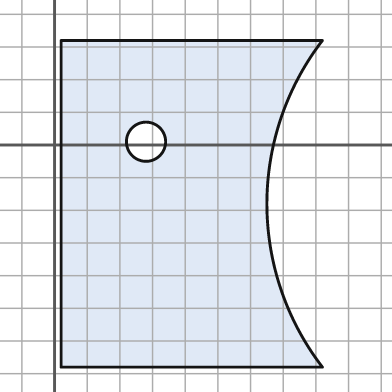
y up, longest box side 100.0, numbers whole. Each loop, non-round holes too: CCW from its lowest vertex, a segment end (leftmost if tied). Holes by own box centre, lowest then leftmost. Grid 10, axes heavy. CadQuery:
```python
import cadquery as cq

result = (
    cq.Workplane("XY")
    .moveTo(2.0, -68.0)
    .lineTo(82.0, -68.0)
    .threePointArc((65.0, -18.0), (82.0, 32.0))
    .lineTo(2.0, 32.0)
    .close()
    .moveTo(28.0, 1.0)
    .circle(6.0)
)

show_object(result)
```